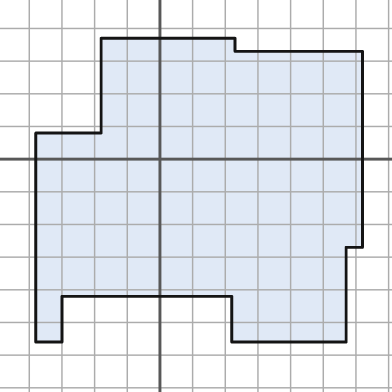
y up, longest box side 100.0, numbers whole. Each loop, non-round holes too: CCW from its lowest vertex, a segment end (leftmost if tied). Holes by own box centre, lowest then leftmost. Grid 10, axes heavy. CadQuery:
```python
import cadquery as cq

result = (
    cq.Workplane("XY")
    .moveTo(-38.0, -56.0)
    .lineTo(-30.0, -56.0)
    .lineTo(-30.0, -42.0)
    .lineTo(22.0, -42.0)
    .lineTo(22.0, -56.0)
    .lineTo(57.0, -56.0)
    .lineTo(57.0, -27.0)
    .lineTo(62.0, -27.0)
    .lineTo(62.0, 33.0)
    .lineTo(23.0, 33.0)
    .lineTo(23.0, 37.0)
    .lineTo(-18.0, 37.0)
    .lineTo(-18.0, 8.0)
    .lineTo(-38.0, 8.0)
    .close()
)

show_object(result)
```